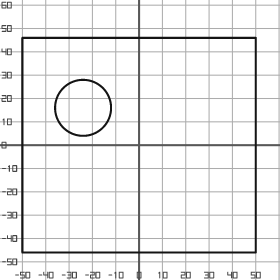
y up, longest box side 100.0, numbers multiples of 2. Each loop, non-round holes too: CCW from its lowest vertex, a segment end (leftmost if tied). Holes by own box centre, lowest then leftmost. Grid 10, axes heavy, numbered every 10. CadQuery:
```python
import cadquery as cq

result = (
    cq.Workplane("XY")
    .moveTo(-50.0, -46.0)
    .lineTo(50.0, -46.0)
    .lineTo(50.0, 46.0)
    .lineTo(-50.0, 46.0)
    .close()
    .moveTo(-24.0, 16.0)
    .circle(12.0)
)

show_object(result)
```